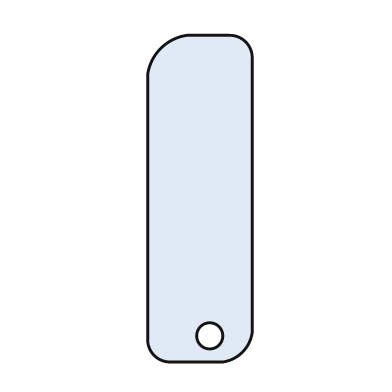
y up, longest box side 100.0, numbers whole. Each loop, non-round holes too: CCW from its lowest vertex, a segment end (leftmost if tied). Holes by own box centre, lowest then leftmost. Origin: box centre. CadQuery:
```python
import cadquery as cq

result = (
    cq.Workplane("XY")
    .moveTo(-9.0, -50.0)
    .lineTo(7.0, -50.0)
    .threePointArc((13.0, -47.0), (16.0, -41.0))
    .lineTo(16.0, 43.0)
    .threePointArc((14.0, 48.0), (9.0, 50.0))
    .lineTo(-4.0, 50.0)
    .threePointArc((-12.0, 46.0), (-16.0, 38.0))
    .lineTo(-16.0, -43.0)
    .threePointArc((-14.0, -48.0), (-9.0, -50.0))
    .close()
    .moveTo(3.0, -42.0)
    .circle(4.0)
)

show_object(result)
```